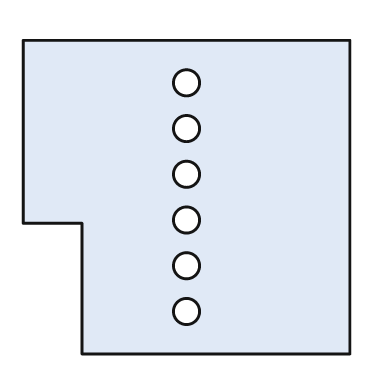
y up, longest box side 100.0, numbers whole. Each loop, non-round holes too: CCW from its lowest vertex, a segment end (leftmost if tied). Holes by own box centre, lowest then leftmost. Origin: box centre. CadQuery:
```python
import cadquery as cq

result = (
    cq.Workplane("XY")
    .moveTo(-32.0, -48.0)
    .lineTo(50.0, -48.0)
    .lineTo(50.0, 48.0)
    .lineTo(-50.0, 48.0)
    .lineTo(-50.0, -8.0)
    .lineTo(-32.0, -8.0)
    .close()
    .moveTo(0.0, -35.0)
    .circle(4.0)
    .moveTo(0.0, -21.0)
    .circle(4.0)
    .moveTo(0.0, -7.0)
    .circle(4.0)
    .moveTo(0.0, 7.0)
    .circle(4.0)
    .moveTo(0.0, 21.0)
    .circle(4.0)
    .moveTo(0.0, 35.0)
    .circle(4.0)
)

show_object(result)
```